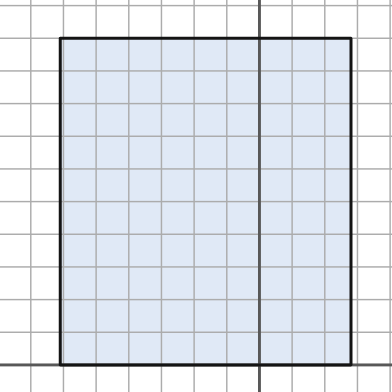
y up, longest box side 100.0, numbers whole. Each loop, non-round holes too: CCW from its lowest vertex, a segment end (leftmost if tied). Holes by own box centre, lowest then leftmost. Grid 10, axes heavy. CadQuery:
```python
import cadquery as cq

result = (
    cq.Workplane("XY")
    .moveTo(-61.0, 0.0)
    .lineTo(28.0, 0.0)
    .lineTo(28.0, 100.0)
    .lineTo(-61.0, 100.0)
    .close()
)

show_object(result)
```